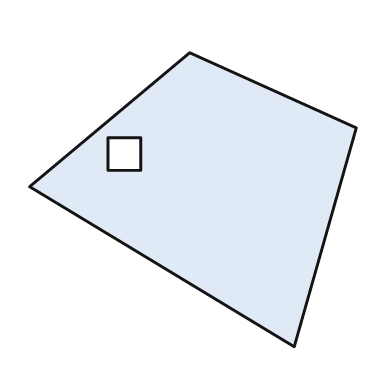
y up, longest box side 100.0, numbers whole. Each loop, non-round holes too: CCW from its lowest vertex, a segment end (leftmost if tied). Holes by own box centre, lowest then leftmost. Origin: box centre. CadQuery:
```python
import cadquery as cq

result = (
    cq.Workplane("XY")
    .moveTo(31.0, -45.0)
    .lineTo(50.0, 22.0)
    .lineTo(-1.0, 45.0)
    .lineTo(-50.0, 4.0)
    .close()
    .moveTo(-26.0, 9.0)
    .lineTo(-16.0, 9.0)
    .lineTo(-16.0, 19.0)
    .lineTo(-26.0, 19.0)
    .close()
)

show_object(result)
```